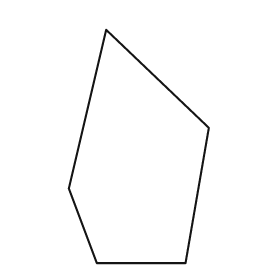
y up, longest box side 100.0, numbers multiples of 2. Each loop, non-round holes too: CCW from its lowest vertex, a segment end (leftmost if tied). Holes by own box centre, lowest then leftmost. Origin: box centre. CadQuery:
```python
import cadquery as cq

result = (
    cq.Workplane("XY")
    .moveTo(-18.0, -50.0)
    .lineTo(20.0, -50.0)
    .lineTo(30.0, 8.0)
    .lineTo(-14.0, 50.0)
    .lineTo(-30.0, -18.0)
    .close()
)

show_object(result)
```